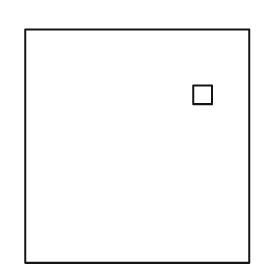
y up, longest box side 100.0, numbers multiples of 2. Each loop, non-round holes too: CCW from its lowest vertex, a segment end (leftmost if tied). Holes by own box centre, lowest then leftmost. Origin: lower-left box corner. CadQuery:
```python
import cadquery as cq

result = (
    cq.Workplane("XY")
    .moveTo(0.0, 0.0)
    .lineTo(96.0, 0.0)
    .lineTo(96.0, 100.0)
    .lineTo(0.0, 100.0)
    .close()
    .moveTo(72.0, 68.0)
    .lineTo(80.0, 68.0)
    .lineTo(80.0, 76.0)
    .lineTo(72.0, 76.0)
    .close()
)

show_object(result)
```